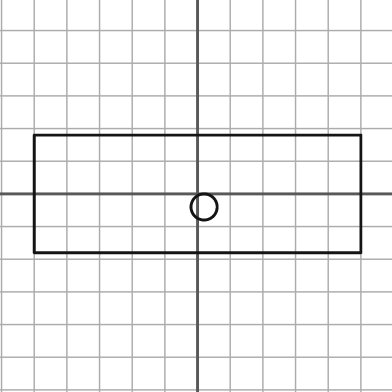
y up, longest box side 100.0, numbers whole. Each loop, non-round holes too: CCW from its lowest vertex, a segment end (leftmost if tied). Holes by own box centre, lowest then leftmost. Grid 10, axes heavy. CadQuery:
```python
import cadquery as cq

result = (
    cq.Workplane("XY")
    .moveTo(-50.0, -18.0)
    .lineTo(50.0, -18.0)
    .lineTo(50.0, 18.0)
    .lineTo(-50.0, 18.0)
    .close()
    .moveTo(2.0, -4.0)
    .circle(4.0)
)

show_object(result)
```